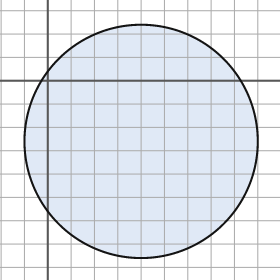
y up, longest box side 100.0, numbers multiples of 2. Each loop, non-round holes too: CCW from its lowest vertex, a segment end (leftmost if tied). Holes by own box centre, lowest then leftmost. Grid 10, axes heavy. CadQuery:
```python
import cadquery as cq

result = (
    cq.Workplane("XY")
    .moveTo(40.0, -26.0)
    .circle(50.0)
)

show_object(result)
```